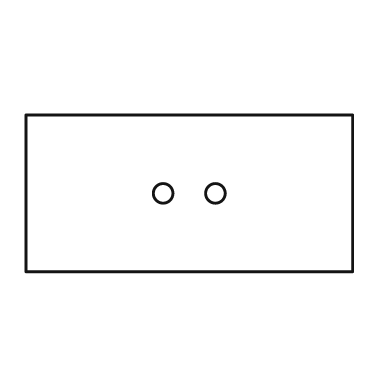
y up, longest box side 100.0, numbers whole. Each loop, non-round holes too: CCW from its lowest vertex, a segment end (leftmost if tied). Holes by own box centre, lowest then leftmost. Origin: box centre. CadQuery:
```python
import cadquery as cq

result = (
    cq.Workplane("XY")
    .moveTo(-50.0, -24.0)
    .lineTo(50.0, -24.0)
    .lineTo(50.0, 24.0)
    .lineTo(-50.0, 24.0)
    .close()
    .moveTo(-8.0, 0.0)
    .circle(3.0)
    .moveTo(8.0, 0.0)
    .circle(3.0)
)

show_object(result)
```